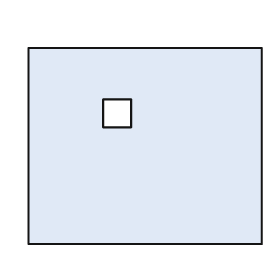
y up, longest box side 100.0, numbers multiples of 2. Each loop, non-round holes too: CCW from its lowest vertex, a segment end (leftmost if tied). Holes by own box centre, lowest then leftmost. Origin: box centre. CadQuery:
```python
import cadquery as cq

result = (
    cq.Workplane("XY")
    .moveTo(-50.0, -42.0)
    .lineTo(50.0, -42.0)
    .lineTo(50.0, 42.0)
    .lineTo(-50.0, 42.0)
    .close()
    .moveTo(-18.0, 8.0)
    .lineTo(-6.0, 8.0)
    .lineTo(-6.0, 20.0)
    .lineTo(-18.0, 20.0)
    .close()
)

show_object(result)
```